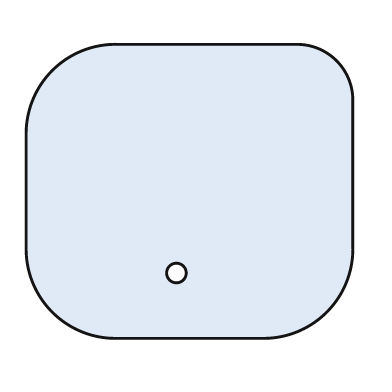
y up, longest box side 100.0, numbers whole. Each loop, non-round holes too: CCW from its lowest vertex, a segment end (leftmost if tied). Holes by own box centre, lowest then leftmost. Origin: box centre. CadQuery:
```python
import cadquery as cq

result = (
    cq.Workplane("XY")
    .moveTo(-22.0, -45.0)
    .lineTo(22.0, -45.0)
    .threePointArc((42.0, -37.0), (50.0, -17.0))
    .lineTo(50.0, 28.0)
    .threePointArc((45.0, 40.0), (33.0, 45.0))
    .lineTo(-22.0, 45.0)
    .threePointArc((-42.0, 37.0), (-50.0, 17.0))
    .lineTo(-50.0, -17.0)
    .threePointArc((-42.0, -37.0), (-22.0, -45.0))
    .close()
    .moveTo(-4.0, -25.0)
    .circle(3.0)
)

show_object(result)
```